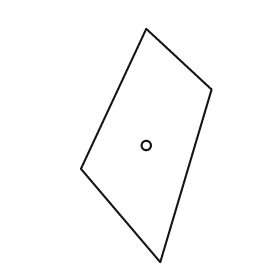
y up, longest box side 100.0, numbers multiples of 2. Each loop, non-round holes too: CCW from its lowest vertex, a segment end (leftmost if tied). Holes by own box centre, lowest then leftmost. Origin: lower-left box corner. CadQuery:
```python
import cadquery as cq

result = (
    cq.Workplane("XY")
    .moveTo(34.0, 0.0)
    .lineTo(56.0, 74.0)
    .lineTo(28.0, 100.0)
    .lineTo(0.0, 40.0)
    .close()
    .moveTo(28.0, 50.0)
    .circle(2.0)
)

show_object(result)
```